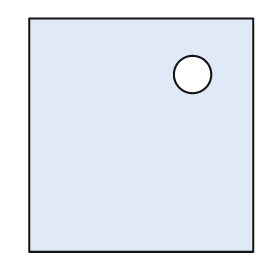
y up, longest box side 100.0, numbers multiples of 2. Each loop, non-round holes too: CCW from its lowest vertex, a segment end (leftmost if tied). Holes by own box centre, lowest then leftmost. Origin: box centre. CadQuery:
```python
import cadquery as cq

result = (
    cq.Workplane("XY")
    .moveTo(-48.0, -50.0)
    .lineTo(48.0, -50.0)
    .lineTo(48.0, 50.0)
    .lineTo(-48.0, 50.0)
    .close()
    .moveTo(22.0, 26.0)
    .circle(8.0)
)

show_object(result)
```